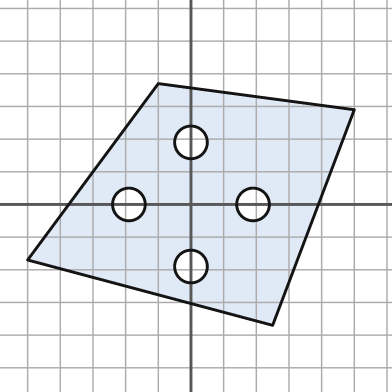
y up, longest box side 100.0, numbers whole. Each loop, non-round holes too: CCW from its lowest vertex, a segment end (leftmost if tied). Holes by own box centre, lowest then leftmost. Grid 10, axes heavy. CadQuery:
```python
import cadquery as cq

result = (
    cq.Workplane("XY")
    .moveTo(25.0, -37.0)
    .lineTo(50.0, 29.0)
    .lineTo(-10.0, 37.0)
    .lineTo(-50.0, -17.0)
    .close()
    .moveTo(0.0, -19.0)
    .circle(5.0)
    .moveTo(-19.0, 0.0)
    .circle(5.0)
    .moveTo(19.0, 0.0)
    .circle(5.0)
    .moveTo(0.0, 19.0)
    .circle(5.0)
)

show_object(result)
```